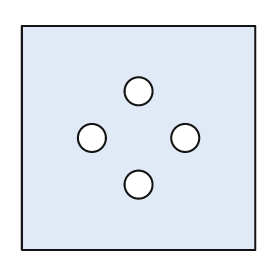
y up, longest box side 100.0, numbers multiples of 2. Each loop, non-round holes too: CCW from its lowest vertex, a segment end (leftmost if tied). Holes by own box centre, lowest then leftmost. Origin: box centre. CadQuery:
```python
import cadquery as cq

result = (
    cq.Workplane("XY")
    .moveTo(-50.0, -48.0)
    .lineTo(50.0, -48.0)
    .lineTo(50.0, 48.0)
    .lineTo(-50.0, 48.0)
    .close()
    .moveTo(0.0, -20.0)
    .circle(6.0)
    .moveTo(-20.0, 0.0)
    .circle(6.0)
    .moveTo(20.0, 0.0)
    .circle(6.0)
    .moveTo(0.0, 20.0)
    .circle(6.0)
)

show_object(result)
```